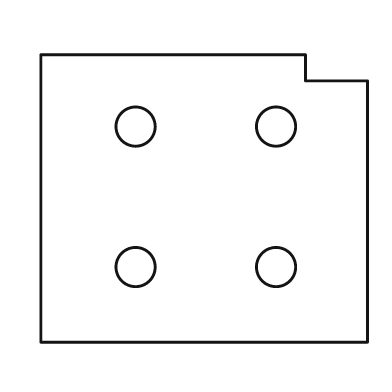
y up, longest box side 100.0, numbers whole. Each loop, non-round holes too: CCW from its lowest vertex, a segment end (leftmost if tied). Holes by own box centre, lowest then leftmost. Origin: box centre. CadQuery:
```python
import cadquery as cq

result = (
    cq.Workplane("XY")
    .moveTo(-50.0, -44.0)
    .lineTo(50.0, -44.0)
    .lineTo(50.0, 36.0)
    .lineTo(31.0, 36.0)
    .lineTo(31.0, 44.0)
    .lineTo(-50.0, 44.0)
    .close()
    .moveTo(-21.0, -21.0)
    .circle(6.0)
    .moveTo(22.0, -21.0)
    .circle(6.0)
    .moveTo(-21.0, 22.0)
    .circle(6.0)
    .moveTo(22.0, 22.0)
    .circle(6.0)
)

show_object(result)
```